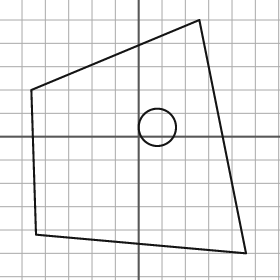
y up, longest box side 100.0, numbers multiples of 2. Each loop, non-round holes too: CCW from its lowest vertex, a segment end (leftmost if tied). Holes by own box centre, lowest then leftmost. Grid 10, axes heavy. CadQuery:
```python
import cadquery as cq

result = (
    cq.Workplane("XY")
    .moveTo(46.0, -50.0)
    .lineTo(26.0, 50.0)
    .lineTo(-46.0, 20.0)
    .lineTo(-44.0, -42.0)
    .close()
    .moveTo(8.0, 4.0)
    .circle(8.0)
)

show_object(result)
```